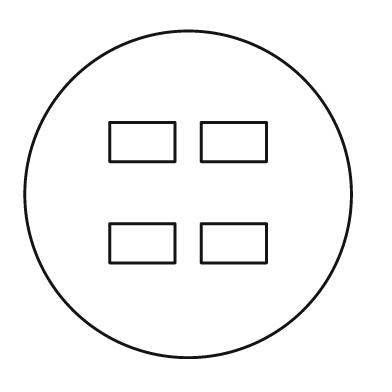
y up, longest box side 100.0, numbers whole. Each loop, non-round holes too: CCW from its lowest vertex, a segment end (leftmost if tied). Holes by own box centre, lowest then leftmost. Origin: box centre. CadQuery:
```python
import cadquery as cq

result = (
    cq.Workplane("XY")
    .moveTo(0.0, 0.0)
    .circle(50.0)
    .moveTo(-24.0, -21.0)
    .lineTo(-4.0, -21.0)
    .lineTo(-4.0, -9.0)
    .lineTo(-24.0, -9.0)
    .close()
    .moveTo(4.0, -21.0)
    .lineTo(24.0, -21.0)
    .lineTo(24.0, -9.0)
    .lineTo(4.0, -9.0)
    .close()
    .moveTo(-24.0, 10.0)
    .lineTo(-4.0, 10.0)
    .lineTo(-4.0, 22.0)
    .lineTo(-24.0, 22.0)
    .close()
    .moveTo(4.0, 10.0)
    .lineTo(24.0, 10.0)
    .lineTo(24.0, 22.0)
    .lineTo(4.0, 22.0)
    .close()
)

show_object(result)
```